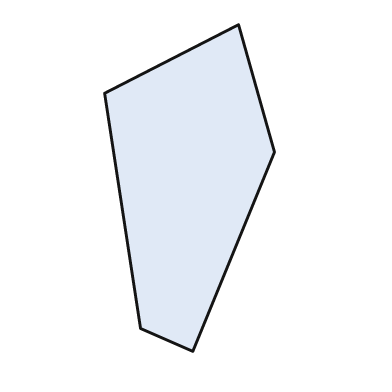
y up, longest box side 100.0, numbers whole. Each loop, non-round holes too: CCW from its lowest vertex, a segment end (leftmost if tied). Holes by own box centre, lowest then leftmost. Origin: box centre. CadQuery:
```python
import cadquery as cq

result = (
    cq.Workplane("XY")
    .moveTo(1.0, -50.0)
    .lineTo(26.0, 11.0)
    .lineTo(15.0, 50.0)
    .lineTo(-26.0, 29.0)
    .lineTo(-15.0, -43.0)
    .close()
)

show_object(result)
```